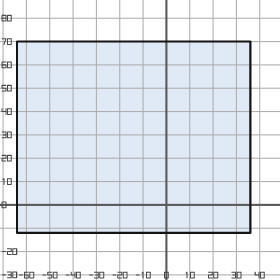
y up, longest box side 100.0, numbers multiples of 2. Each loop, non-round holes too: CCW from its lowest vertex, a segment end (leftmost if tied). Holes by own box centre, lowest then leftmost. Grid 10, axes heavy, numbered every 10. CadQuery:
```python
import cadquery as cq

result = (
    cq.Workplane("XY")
    .moveTo(-64.0, -12.0)
    .lineTo(36.0, -12.0)
    .lineTo(36.0, 70.0)
    .lineTo(-64.0, 70.0)
    .close()
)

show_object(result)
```